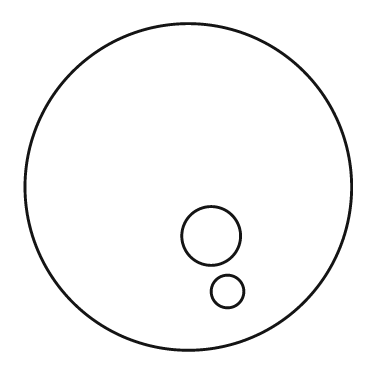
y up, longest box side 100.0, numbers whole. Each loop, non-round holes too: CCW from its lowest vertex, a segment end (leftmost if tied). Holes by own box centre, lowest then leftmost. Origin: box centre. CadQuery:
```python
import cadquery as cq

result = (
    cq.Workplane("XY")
    .moveTo(0.0, 0.0)
    .circle(50.0)
    .moveTo(12.0, -32.0)
    .circle(5.0)
    .moveTo(7.0, -15.0)
    .circle(9.0)
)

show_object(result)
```